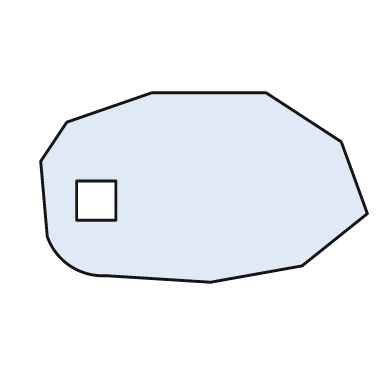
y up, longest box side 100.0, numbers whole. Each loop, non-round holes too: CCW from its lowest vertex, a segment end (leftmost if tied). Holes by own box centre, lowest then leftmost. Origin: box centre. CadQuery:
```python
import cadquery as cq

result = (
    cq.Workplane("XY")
    .moveTo(2.0, -29.0)
    .lineTo(30.0, -24.0)
    .lineTo(50.0, -8.0)
    .lineTo(42.0, 14.0)
    .lineTo(19.0, 29.0)
    .lineTo(-16.0, 29.0)
    .lineTo(-42.0, 20.0)
    .lineTo(-50.0, 8.0)
    .lineTo(-48.0, -15.0)
    .threePointArc((-41.0, -24.0), (-30.0, -27.0))
    .close()
    .moveTo(-39.0, -10.0)
    .lineTo(-27.0, -10.0)
    .lineTo(-27.0, 2.0)
    .lineTo(-39.0, 2.0)
    .close()
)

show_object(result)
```